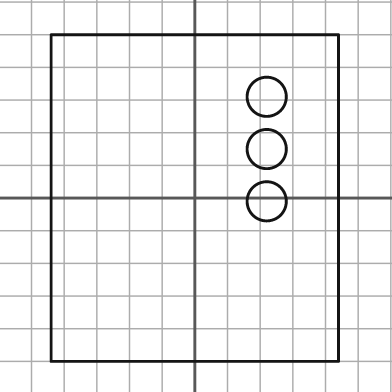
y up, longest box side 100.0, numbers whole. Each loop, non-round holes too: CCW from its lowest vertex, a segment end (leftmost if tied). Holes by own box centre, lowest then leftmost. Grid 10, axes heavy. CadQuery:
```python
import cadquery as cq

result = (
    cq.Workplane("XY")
    .moveTo(-44.0, -50.0)
    .lineTo(44.0, -50.0)
    .lineTo(44.0, 50.0)
    .lineTo(-44.0, 50.0)
    .close()
    .moveTo(22.0, -1.0)
    .circle(6.0)
    .moveTo(22.0, 15.0)
    .circle(6.0)
    .moveTo(22.0, 31.0)
    .circle(6.0)
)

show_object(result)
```